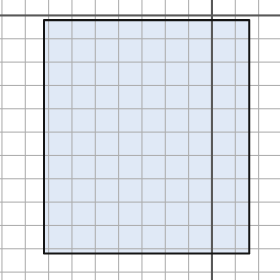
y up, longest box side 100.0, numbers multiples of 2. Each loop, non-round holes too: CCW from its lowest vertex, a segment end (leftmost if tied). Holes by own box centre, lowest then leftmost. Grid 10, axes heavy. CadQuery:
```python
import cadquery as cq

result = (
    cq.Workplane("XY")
    .moveTo(-72.0, -102.0)
    .lineTo(16.0, -102.0)
    .lineTo(16.0, -2.0)
    .lineTo(-72.0, -2.0)
    .close()
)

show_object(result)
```